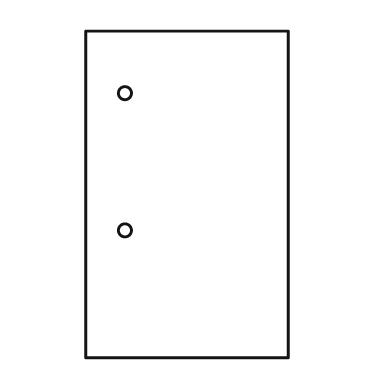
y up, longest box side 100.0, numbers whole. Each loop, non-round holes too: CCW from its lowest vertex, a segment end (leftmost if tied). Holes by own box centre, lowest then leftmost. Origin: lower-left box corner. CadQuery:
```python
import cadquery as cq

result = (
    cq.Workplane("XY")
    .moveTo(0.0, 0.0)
    .lineTo(62.0, 0.0)
    .lineTo(62.0, 100.0)
    .lineTo(0.0, 100.0)
    .close()
    .moveTo(12.0, 39.0)
    .circle(2.0)
    .moveTo(12.0, 81.0)
    .circle(2.0)
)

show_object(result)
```